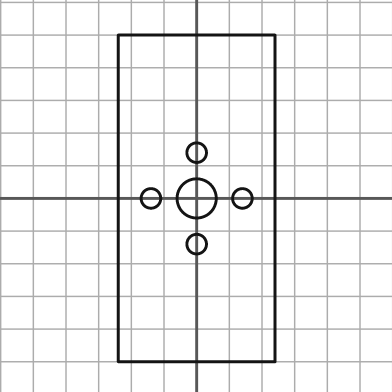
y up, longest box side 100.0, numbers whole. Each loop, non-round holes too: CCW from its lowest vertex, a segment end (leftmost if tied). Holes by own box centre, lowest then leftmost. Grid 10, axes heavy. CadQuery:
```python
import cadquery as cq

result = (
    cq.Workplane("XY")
    .moveTo(-24.0, -50.0)
    .lineTo(24.0, -50.0)
    .lineTo(24.0, 50.0)
    .lineTo(-24.0, 50.0)
    .close()
    .moveTo(0.0, -14.0)
    .circle(3.0)
    .moveTo(-14.0, 0.0)
    .circle(3.0)
    .moveTo(0.0, 0.0)
    .circle(6.0)
    .moveTo(14.0, 0.0)
    .circle(3.0)
    .moveTo(0.0, 14.0)
    .circle(3.0)
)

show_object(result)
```